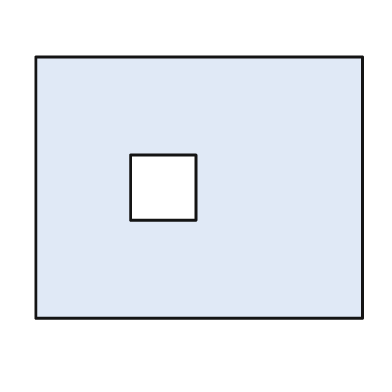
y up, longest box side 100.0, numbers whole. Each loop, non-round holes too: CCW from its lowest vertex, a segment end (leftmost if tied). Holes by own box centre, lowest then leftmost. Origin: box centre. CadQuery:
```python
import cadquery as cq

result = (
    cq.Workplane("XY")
    .moveTo(-50.0, -40.0)
    .lineTo(50.0, -40.0)
    .lineTo(50.0, 40.0)
    .lineTo(-50.0, 40.0)
    .close()
    .moveTo(-21.0, -10.0)
    .lineTo(-1.0, -10.0)
    .lineTo(-1.0, 10.0)
    .lineTo(-21.0, 10.0)
    .close()
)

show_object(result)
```